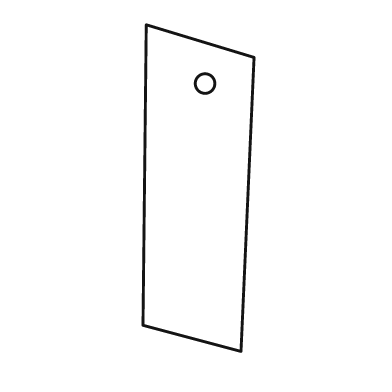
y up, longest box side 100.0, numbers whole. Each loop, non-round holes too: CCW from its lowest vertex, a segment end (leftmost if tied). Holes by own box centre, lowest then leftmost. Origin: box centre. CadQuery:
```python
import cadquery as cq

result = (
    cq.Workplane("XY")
    .moveTo(13.0, -50.0)
    .lineTo(17.0, 40.0)
    .lineTo(-16.0, 50.0)
    .lineTo(-17.0, -42.0)
    .close()
    .moveTo(2.0, 32.0)
    .circle(3.0)
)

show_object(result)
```